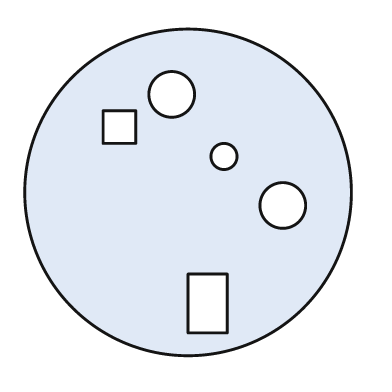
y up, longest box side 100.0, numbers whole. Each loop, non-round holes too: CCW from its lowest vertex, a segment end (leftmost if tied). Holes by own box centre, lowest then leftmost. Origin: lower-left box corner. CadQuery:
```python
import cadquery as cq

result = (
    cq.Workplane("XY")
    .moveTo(50.0, 50.0)
    .circle(50.0)
    .moveTo(50.0, 7.0)
    .lineTo(62.0, 7.0)
    .lineTo(62.0, 25.0)
    .lineTo(50.0, 25.0)
    .close()
    .moveTo(79.0, 46.0)
    .circle(7.0)
    .moveTo(61.0, 61.0)
    .circle(4.0)
    .moveTo(24.0, 65.0)
    .lineTo(34.0, 65.0)
    .lineTo(34.0, 75.0)
    .lineTo(24.0, 75.0)
    .close()
    .moveTo(45.0, 80.0)
    .circle(7.0)
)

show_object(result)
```